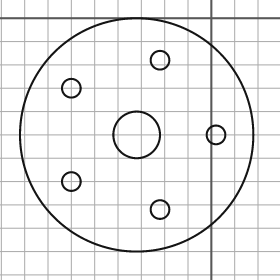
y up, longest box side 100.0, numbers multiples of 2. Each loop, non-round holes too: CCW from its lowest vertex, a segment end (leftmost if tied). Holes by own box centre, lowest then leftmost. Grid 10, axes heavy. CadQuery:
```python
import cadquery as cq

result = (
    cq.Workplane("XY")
    .moveTo(-32.0, -50.0)
    .circle(50.0)
    .moveTo(-22.0, -82.0)
    .circle(4.0)
    .moveTo(-60.0, -70.0)
    .circle(4.0)
    .moveTo(-32.0, -50.0)
    .circle(10.0)
    .moveTo(2.0, -50.0)
    .circle(4.0)
    .moveTo(-60.0, -30.0)
    .circle(4.0)
    .moveTo(-22.0, -18.0)
    .circle(4.0)
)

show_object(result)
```